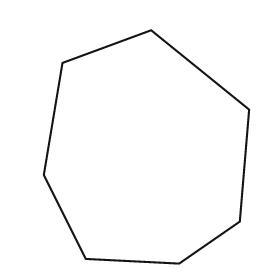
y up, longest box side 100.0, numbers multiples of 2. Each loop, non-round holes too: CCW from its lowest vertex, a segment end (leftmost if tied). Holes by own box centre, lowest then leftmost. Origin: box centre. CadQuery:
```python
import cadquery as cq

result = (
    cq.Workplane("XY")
    .moveTo(14.0, -50.0)
    .lineTo(40.0, -32.0)
    .lineTo(44.0, 16.0)
    .lineTo(2.0, 50.0)
    .lineTo(-36.0, 36.0)
    .lineTo(-44.0, -12.0)
    .lineTo(-26.0, -48.0)
    .close()
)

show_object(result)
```